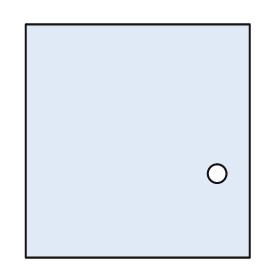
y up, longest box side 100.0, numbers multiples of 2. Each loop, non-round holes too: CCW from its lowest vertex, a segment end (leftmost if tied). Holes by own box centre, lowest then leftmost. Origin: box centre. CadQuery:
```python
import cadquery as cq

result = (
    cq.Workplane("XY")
    .moveTo(-48.0, -50.0)
    .lineTo(48.0, -50.0)
    .lineTo(48.0, 50.0)
    .lineTo(-48.0, 50.0)
    .close()
    .moveTo(34.0, -14.0)
    .circle(4.0)
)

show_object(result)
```